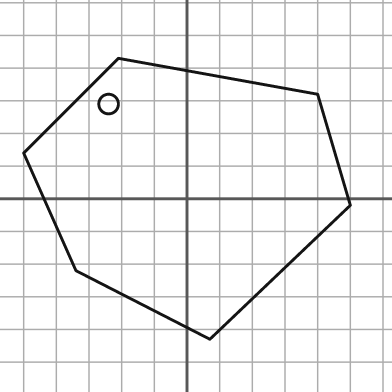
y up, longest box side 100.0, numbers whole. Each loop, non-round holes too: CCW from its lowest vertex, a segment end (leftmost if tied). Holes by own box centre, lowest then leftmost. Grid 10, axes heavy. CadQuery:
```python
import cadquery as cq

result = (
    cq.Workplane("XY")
    .moveTo(7.0, -43.0)
    .lineTo(50.0, -2.0)
    .lineTo(40.0, 32.0)
    .lineTo(-21.0, 43.0)
    .lineTo(-50.0, 14.0)
    .lineTo(-34.0, -22.0)
    .close()
    .moveTo(-24.0, 29.0)
    .circle(3.0)
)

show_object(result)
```